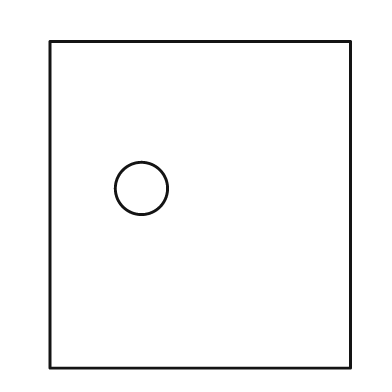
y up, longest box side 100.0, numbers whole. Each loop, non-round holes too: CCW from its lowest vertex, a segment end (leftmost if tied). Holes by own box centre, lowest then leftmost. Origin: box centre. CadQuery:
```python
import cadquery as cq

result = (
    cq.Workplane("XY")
    .moveTo(-46.0, -50.0)
    .lineTo(46.0, -50.0)
    .lineTo(46.0, 50.0)
    .lineTo(-46.0, 50.0)
    .close()
    .moveTo(-18.0, 5.0)
    .circle(8.0)
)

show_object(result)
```